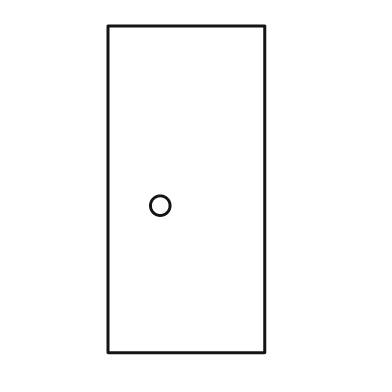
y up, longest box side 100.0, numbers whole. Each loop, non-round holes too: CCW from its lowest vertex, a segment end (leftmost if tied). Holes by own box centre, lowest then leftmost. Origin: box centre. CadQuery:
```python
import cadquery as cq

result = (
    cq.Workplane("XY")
    .moveTo(-24.0, -50.0)
    .lineTo(24.0, -50.0)
    .lineTo(24.0, 50.0)
    .lineTo(-24.0, 50.0)
    .close()
    .moveTo(-8.0, -5.0)
    .circle(3.0)
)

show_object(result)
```